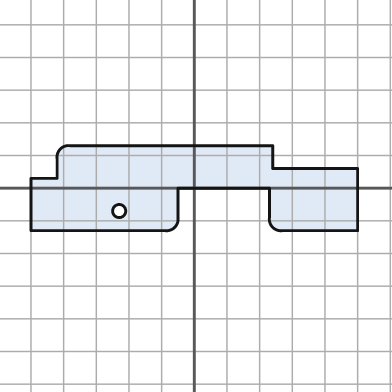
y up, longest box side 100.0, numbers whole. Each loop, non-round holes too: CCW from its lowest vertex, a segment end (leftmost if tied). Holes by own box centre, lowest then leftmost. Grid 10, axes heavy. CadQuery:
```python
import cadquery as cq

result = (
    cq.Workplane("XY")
    .moveTo(-50.0, -13.0)
    .lineTo(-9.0, -13.0)
    .threePointArc((-6.0, -12.0), (-5.0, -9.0))
    .lineTo(-5.0, 0.0)
    .lineTo(23.0, 0.0)
    .lineTo(23.0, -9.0)
    .threePointArc((24.0, -12.0), (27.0, -13.0))
    .lineTo(50.0, -13.0)
    .lineTo(50.0, 6.0)
    .lineTo(24.0, 6.0)
    .lineTo(24.0, 13.0)
    .lineTo(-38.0, 13.0)
    .threePointArc((-41.0, 12.0), (-42.0, 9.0))
    .lineTo(-42.0, 3.0)
    .lineTo(-50.0, 3.0)
    .close()
    .moveTo(-23.0, -7.0)
    .circle(2.0)
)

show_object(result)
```